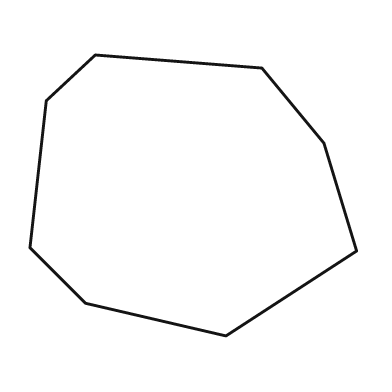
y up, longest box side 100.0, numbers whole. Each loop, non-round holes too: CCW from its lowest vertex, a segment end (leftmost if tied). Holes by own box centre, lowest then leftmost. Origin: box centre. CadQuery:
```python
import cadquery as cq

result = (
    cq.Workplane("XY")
    .moveTo(10.0, -43.0)
    .lineTo(50.0, -17.0)
    .lineTo(40.0, 16.0)
    .lineTo(21.0, 39.0)
    .lineTo(-30.0, 43.0)
    .lineTo(-45.0, 29.0)
    .lineTo(-50.0, -16.0)
    .lineTo(-33.0, -33.0)
    .close()
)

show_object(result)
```